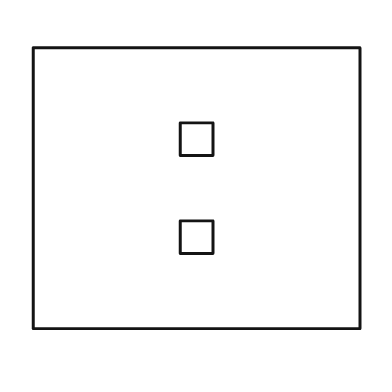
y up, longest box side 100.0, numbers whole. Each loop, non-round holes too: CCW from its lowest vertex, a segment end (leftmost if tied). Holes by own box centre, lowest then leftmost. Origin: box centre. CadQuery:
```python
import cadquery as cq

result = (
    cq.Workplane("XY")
    .moveTo(-50.0, -43.0)
    .lineTo(50.0, -43.0)
    .lineTo(50.0, 43.0)
    .lineTo(-50.0, 43.0)
    .close()
    .moveTo(-5.0, -20.0)
    .lineTo(5.0, -20.0)
    .lineTo(5.0, -10.0)
    .lineTo(-5.0, -10.0)
    .close()
    .moveTo(-5.0, 10.0)
    .lineTo(5.0, 10.0)
    .lineTo(5.0, 20.0)
    .lineTo(-5.0, 20.0)
    .close()
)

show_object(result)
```